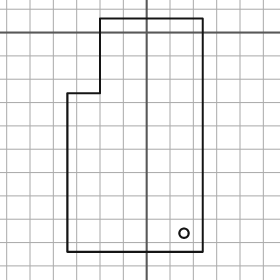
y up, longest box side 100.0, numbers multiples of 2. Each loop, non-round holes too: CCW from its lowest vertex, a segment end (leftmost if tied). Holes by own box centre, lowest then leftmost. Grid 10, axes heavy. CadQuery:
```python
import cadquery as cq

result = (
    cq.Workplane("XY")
    .moveTo(-34.0, -94.0)
    .lineTo(24.0, -94.0)
    .lineTo(24.0, 6.0)
    .lineTo(-20.0, 6.0)
    .lineTo(-20.0, -26.0)
    .lineTo(-34.0, -26.0)
    .close()
    .moveTo(16.0, -86.0)
    .circle(2.0)
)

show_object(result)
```